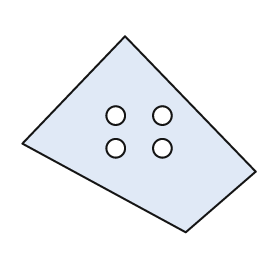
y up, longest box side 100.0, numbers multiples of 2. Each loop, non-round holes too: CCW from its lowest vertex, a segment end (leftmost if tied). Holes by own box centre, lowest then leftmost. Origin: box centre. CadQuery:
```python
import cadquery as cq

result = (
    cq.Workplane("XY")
    .moveTo(20.0, -42.0)
    .lineTo(50.0, -16.0)
    .lineTo(-6.0, 42.0)
    .lineTo(-50.0, -4.0)
    .close()
    .moveTo(-10.0, -6.0)
    .circle(4.0)
    .moveTo(10.0, -6.0)
    .circle(4.0)
    .moveTo(-10.0, 8.0)
    .circle(4.0)
    .moveTo(10.0, 8.0)
    .circle(4.0)
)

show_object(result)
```